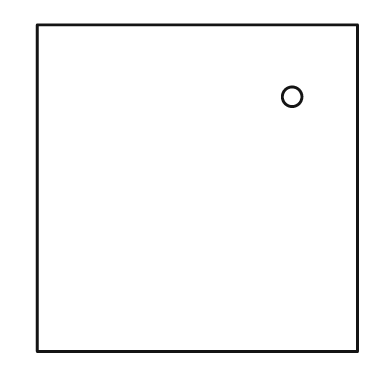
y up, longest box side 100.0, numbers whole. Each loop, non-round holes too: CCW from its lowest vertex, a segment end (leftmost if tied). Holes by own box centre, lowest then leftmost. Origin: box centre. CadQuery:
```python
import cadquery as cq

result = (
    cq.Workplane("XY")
    .moveTo(-49.0, -50.0)
    .lineTo(49.0, -50.0)
    .lineTo(49.0, 50.0)
    .lineTo(-49.0, 50.0)
    .close()
    .moveTo(29.0, 28.0)
    .circle(3.0)
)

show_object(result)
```